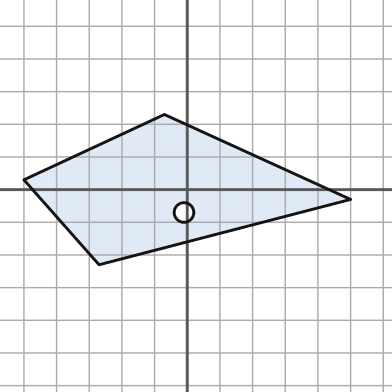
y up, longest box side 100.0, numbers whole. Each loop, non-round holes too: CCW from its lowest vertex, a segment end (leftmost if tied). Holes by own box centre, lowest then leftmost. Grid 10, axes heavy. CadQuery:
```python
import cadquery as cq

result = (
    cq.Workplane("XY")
    .moveTo(-27.0, -23.0)
    .lineTo(50.0, -3.0)
    .lineTo(-7.0, 23.0)
    .lineTo(-50.0, 3.0)
    .close()
    .moveTo(-1.0, -7.0)
    .circle(3.0)
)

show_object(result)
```